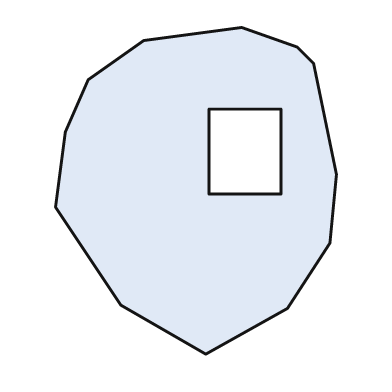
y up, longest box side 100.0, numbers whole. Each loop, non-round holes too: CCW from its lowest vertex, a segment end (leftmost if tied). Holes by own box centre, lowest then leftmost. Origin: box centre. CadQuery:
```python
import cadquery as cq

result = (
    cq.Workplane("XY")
    .moveTo(3.0, -50.0)
    .lineTo(28.0, -36.0)
    .lineTo(41.0, -16.0)
    .lineTo(43.0, 5.0)
    .lineTo(36.0, 39.0)
    .lineTo(31.0, 44.0)
    .lineTo(14.0, 50.0)
    .lineTo(-16.0, 46.0)
    .lineTo(-33.0, 34.0)
    .lineTo(-40.0, 18.0)
    .lineTo(-43.0, -5.0)
    .lineTo(-23.0, -35.0)
    .close()
    .moveTo(4.0, -1.0)
    .lineTo(26.0, -1.0)
    .lineTo(26.0, 25.0)
    .lineTo(4.0, 25.0)
    .close()
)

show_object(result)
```